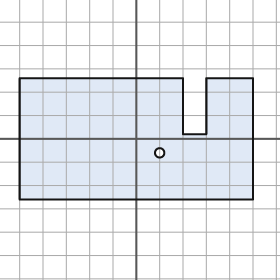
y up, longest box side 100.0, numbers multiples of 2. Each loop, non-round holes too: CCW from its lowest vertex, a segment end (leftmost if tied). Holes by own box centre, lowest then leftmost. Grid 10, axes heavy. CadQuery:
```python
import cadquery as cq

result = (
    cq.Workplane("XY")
    .moveTo(-50.0, -26.0)
    .lineTo(50.0, -26.0)
    .lineTo(50.0, 26.0)
    .lineTo(30.0, 26.0)
    .lineTo(30.0, 2.0)
    .lineTo(20.0, 2.0)
    .lineTo(20.0, 26.0)
    .lineTo(-50.0, 26.0)
    .close()
    .moveTo(10.0, -6.0)
    .circle(2.0)
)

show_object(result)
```